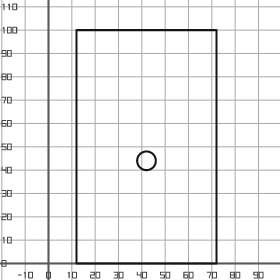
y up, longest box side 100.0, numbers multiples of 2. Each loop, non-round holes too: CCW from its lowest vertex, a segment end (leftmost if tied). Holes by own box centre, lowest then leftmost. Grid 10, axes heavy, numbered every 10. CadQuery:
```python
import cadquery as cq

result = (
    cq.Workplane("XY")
    .moveTo(12.0, 0.0)
    .lineTo(72.0, 0.0)
    .lineTo(72.0, 100.0)
    .lineTo(12.0, 100.0)
    .close()
    .moveTo(42.0, 44.0)
    .circle(4.0)
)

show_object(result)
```